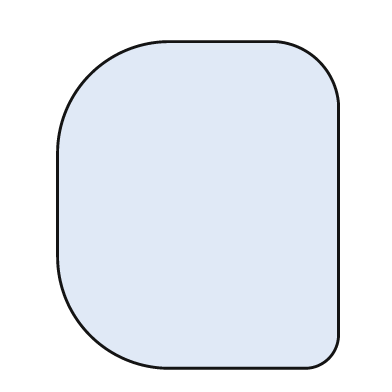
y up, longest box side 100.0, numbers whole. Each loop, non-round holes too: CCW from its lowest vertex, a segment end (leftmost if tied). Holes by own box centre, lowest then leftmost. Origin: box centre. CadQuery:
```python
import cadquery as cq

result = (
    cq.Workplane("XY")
    .moveTo(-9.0, -50.0)
    .lineTo(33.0, -50.0)
    .threePointArc((40.0, -47.0), (43.0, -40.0))
    .lineTo(43.0, 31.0)
    .threePointArc((37.0, 44.0), (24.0, 50.0))
    .lineTo(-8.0, 50.0)
    .threePointArc((-33.0, 40.0), (-43.0, 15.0))
    .lineTo(-43.0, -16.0)
    .threePointArc((-33.0, -40.0), (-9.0, -50.0))
    .close()
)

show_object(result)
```